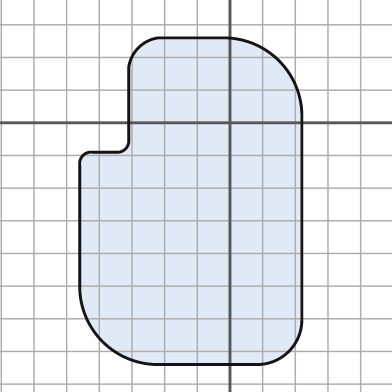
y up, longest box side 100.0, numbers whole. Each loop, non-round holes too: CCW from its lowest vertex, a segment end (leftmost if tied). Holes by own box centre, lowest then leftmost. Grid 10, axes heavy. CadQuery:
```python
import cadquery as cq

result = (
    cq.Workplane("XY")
    .moveTo(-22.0, -74.0)
    .lineTo(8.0, -74.0)
    .threePointArc((18.0, -70.0), (22.0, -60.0))
    .lineTo(22.0, 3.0)
    .threePointArc((15.0, 19.0), (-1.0, 26.0))
    .lineTo(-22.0, 26.0)
    .threePointArc((-28.0, 23.0), (-31.0, 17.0))
    .lineTo(-31.0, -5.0)
    .threePointArc((-32.0, -8.0), (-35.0, -9.0))
    .lineTo(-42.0, -9.0)
    .threePointArc((-45.0, -10.0), (-46.0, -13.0))
    .lineTo(-46.0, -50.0)
    .threePointArc((-39.0, -67.0), (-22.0, -74.0))
    .close()
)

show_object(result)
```